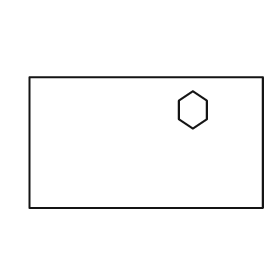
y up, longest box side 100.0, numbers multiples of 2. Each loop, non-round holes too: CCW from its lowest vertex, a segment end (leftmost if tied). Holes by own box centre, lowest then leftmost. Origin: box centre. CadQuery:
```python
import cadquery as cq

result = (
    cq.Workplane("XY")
    .moveTo(-50.0, -28.0)
    .lineTo(50.0, -28.0)
    .lineTo(50.0, 28.0)
    .lineTo(-50.0, 28.0)
    .close()
    .moveTo(20.0, 6.0)
    .lineTo(26.0, 10.0)
    .lineTo(26.0, 18.0)
    .lineTo(20.0, 22.0)
    .lineTo(14.0, 18.0)
    .lineTo(14.0, 10.0)
    .close()
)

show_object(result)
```